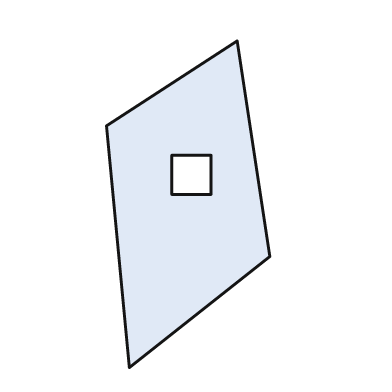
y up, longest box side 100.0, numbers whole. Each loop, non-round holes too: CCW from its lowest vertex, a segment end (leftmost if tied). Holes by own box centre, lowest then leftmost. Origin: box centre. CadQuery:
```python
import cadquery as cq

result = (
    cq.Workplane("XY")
    .moveTo(-18.0, -50.0)
    .lineTo(25.0, -16.0)
    .lineTo(15.0, 50.0)
    .lineTo(-25.0, 24.0)
    .close()
    .moveTo(-5.0, 3.0)
    .lineTo(7.0, 3.0)
    .lineTo(7.0, 15.0)
    .lineTo(-5.0, 15.0)
    .close()
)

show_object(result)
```